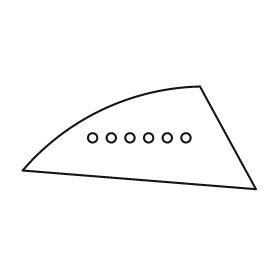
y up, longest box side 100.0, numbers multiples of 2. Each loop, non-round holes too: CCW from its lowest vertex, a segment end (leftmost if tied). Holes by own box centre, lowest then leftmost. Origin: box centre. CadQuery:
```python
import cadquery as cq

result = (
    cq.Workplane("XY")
    .moveTo(50.0, -22.0)
    .lineTo(26.0, 22.0)
    .threePointArc((-16.0, 12.0), (-50.0, -14.0))
    .close()
    .moveTo(-20.0, 0.0)
    .circle(2.0)
    .moveTo(-12.0, 0.0)
    .circle(2.0)
    .moveTo(-4.0, 0.0)
    .circle(2.0)
    .moveTo(4.0, 0.0)
    .circle(2.0)
    .moveTo(12.0, 0.0)
    .circle(2.0)
    .moveTo(20.0, 0.0)
    .circle(2.0)
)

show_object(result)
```